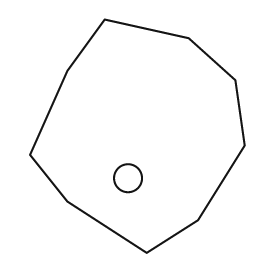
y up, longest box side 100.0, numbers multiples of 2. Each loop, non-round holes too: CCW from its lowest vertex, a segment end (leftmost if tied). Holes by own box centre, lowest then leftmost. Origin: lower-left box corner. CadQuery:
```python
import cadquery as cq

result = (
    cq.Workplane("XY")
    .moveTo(50.0, 0.0)
    .lineTo(72.0, 14.0)
    .lineTo(92.0, 46.0)
    .lineTo(88.0, 74.0)
    .lineTo(68.0, 92.0)
    .lineTo(32.0, 100.0)
    .lineTo(16.0, 78.0)
    .lineTo(0.0, 42.0)
    .lineTo(16.0, 22.0)
    .close()
    .moveTo(42.0, 32.0)
    .circle(6.0)
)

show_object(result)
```